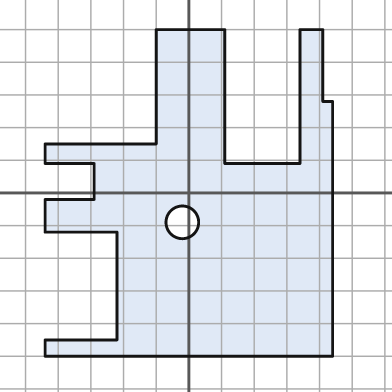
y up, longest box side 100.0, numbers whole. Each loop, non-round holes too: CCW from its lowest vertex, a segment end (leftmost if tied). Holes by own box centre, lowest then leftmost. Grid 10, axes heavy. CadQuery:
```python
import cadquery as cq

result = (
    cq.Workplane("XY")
    .moveTo(-44.0, -50.0)
    .lineTo(44.0, -50.0)
    .lineTo(44.0, 28.0)
    .lineTo(41.0, 28.0)
    .lineTo(41.0, 50.0)
    .lineTo(34.0, 50.0)
    .lineTo(34.0, 9.0)
    .lineTo(11.0, 9.0)
    .lineTo(11.0, 50.0)
    .lineTo(-10.0, 50.0)
    .lineTo(-10.0, 15.0)
    .lineTo(-44.0, 15.0)
    .lineTo(-44.0, 9.0)
    .lineTo(-29.0, 9.0)
    .lineTo(-29.0, -2.0)
    .lineTo(-44.0, -2.0)
    .lineTo(-44.0, -12.0)
    .lineTo(-22.0, -12.0)
    .lineTo(-22.0, -45.0)
    .lineTo(-44.0, -45.0)
    .close()
    .moveTo(-2.0, -9.0)
    .circle(5.0)
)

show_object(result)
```